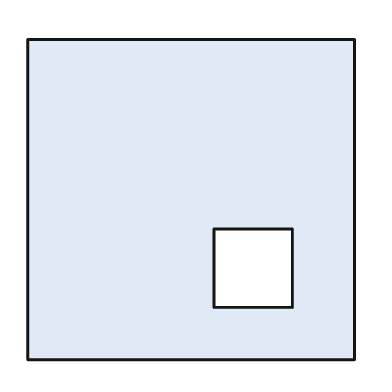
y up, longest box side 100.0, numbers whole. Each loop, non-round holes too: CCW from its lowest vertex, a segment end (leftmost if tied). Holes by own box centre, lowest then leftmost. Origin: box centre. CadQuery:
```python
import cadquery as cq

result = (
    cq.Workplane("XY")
    .moveTo(-50.0, -49.0)
    .lineTo(50.0, -49.0)
    .lineTo(50.0, 49.0)
    .lineTo(-50.0, 49.0)
    .close()
    .moveTo(7.0, -33.0)
    .lineTo(31.0, -33.0)
    .lineTo(31.0, -9.0)
    .lineTo(7.0, -9.0)
    .close()
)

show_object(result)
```